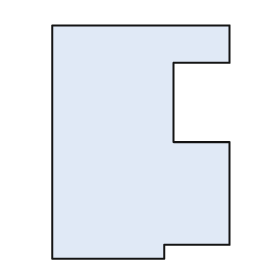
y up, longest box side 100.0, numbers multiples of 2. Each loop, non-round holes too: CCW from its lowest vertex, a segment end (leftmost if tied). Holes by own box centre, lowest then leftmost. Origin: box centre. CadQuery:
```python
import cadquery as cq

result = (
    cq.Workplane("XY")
    .moveTo(-38.0, -50.0)
    .lineTo(10.0, -50.0)
    .lineTo(10.0, -44.0)
    .lineTo(38.0, -44.0)
    .lineTo(38.0, 0.0)
    .lineTo(14.0, 0.0)
    .lineTo(14.0, 34.0)
    .lineTo(38.0, 34.0)
    .lineTo(38.0, 50.0)
    .lineTo(-38.0, 50.0)
    .close()
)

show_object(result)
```